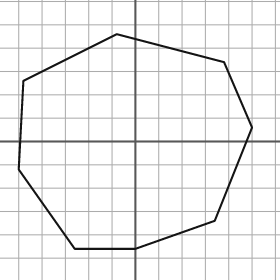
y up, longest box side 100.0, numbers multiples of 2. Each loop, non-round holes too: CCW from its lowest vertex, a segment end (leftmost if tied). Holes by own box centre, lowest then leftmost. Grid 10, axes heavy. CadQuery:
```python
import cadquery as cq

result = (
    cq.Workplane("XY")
    .moveTo(-26.0, -46.0)
    .lineTo(0.0, -46.0)
    .lineTo(34.0, -34.0)
    .lineTo(50.0, 6.0)
    .lineTo(38.0, 34.0)
    .lineTo(-8.0, 46.0)
    .lineTo(-48.0, 26.0)
    .lineTo(-50.0, -12.0)
    .close()
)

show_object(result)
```